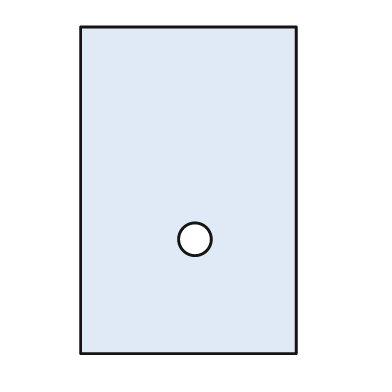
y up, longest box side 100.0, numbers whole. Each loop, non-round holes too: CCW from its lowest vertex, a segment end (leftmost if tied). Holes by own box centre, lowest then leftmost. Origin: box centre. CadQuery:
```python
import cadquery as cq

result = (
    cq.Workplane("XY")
    .moveTo(-33.0, -50.0)
    .lineTo(33.0, -50.0)
    .lineTo(33.0, 50.0)
    .lineTo(-33.0, 50.0)
    .close()
    .moveTo(2.0, -15.0)
    .circle(5.0)
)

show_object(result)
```